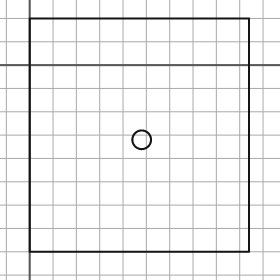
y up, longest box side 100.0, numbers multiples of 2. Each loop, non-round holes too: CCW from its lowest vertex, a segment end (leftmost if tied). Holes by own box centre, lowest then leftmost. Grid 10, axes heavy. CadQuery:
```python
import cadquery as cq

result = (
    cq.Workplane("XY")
    .moveTo(0.0, -80.0)
    .lineTo(94.0, -80.0)
    .lineTo(94.0, 20.0)
    .lineTo(0.0, 20.0)
    .close()
    .moveTo(48.0, -32.0)
    .circle(4.0)
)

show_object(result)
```